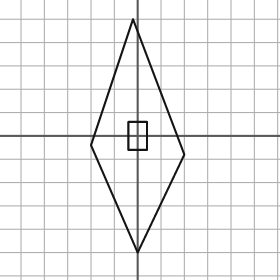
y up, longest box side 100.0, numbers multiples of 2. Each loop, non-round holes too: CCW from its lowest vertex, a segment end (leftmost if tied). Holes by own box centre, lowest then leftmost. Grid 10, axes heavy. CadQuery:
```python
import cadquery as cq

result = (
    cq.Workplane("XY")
    .moveTo(0.0, -50.0)
    .lineTo(20.0, -8.0)
    .lineTo(-2.0, 50.0)
    .lineTo(-20.0, -4.0)
    .close()
    .moveTo(-4.0, -6.0)
    .lineTo(4.0, -6.0)
    .lineTo(4.0, 6.0)
    .lineTo(-4.0, 6.0)
    .close()
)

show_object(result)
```